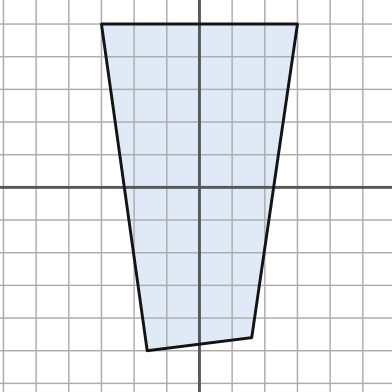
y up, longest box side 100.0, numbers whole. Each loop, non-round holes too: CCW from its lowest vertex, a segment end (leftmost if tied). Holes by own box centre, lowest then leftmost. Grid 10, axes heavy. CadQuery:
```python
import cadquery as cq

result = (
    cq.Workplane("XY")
    .moveTo(-16.0, -50.0)
    .lineTo(16.0, -46.0)
    .lineTo(30.0, 50.0)
    .lineTo(-30.0, 50.0)
    .close()
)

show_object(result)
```